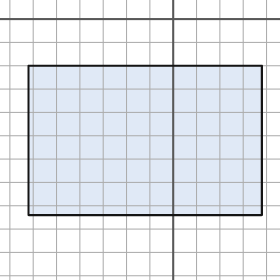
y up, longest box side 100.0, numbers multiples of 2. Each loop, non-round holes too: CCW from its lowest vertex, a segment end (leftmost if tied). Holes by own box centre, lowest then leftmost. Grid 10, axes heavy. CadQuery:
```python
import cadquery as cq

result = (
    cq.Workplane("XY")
    .moveTo(-62.0, -84.0)
    .lineTo(38.0, -84.0)
    .lineTo(38.0, -20.0)
    .lineTo(-62.0, -20.0)
    .close()
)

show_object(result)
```